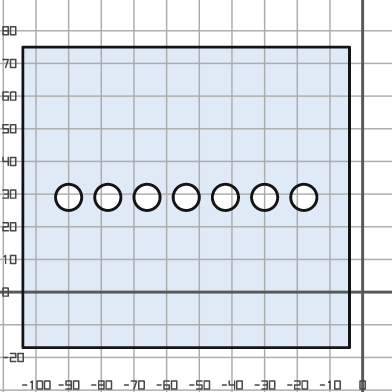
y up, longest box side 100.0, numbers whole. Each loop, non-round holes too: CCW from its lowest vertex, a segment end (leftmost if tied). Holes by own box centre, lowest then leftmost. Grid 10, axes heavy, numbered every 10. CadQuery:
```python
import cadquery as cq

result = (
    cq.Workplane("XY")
    .moveTo(-104.0, -17.0)
    .lineTo(-4.0, -17.0)
    .lineTo(-4.0, 75.0)
    .lineTo(-104.0, 75.0)
    .close()
    .moveTo(-90.0, 29.0)
    .circle(4.0)
    .moveTo(-78.0, 29.0)
    .circle(4.0)
    .moveTo(-66.0, 29.0)
    .circle(4.0)
    .moveTo(-54.0, 29.0)
    .circle(4.0)
    .moveTo(-42.0, 29.0)
    .circle(4.0)
    .moveTo(-30.0, 29.0)
    .circle(4.0)
    .moveTo(-18.0, 29.0)
    .circle(4.0)
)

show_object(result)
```